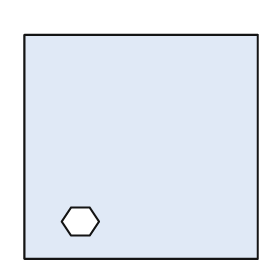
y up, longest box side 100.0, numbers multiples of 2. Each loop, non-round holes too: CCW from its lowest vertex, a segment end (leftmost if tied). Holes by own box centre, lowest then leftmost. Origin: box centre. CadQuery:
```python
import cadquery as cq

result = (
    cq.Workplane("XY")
    .moveTo(-50.0, -48.0)
    .lineTo(50.0, -48.0)
    .lineTo(50.0, 48.0)
    .lineTo(-50.0, 48.0)
    .close()
    .moveTo(-30.0, -38.0)
    .lineTo(-22.0, -38.0)
    .lineTo(-18.0, -32.0)
    .lineTo(-22.0, -26.0)
    .lineTo(-30.0, -26.0)
    .lineTo(-34.0, -32.0)
    .close()
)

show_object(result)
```